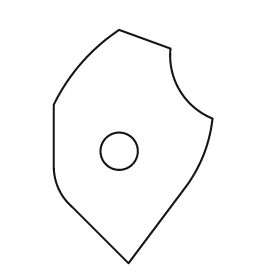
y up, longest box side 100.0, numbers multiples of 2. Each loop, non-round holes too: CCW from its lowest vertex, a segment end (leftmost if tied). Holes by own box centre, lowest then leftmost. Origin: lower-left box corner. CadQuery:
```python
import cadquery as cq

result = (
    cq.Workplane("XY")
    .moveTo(32.0, 0.0)
    .lineTo(56.0, 32.0)
    .threePointArc((64.0, 46.0), (68.0, 62.0))
    .threePointArc((54.0, 74.0), (50.0, 92.0))
    .lineTo(28.0, 100.0)
    .threePointArc((12.0, 86.0), (0.0, 68.0))
    .lineTo(0.0, 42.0)
    .threePointArc((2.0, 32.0), (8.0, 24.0))
    .close()
    .moveTo(28.0, 48.0)
    .circle(8.0)
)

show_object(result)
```